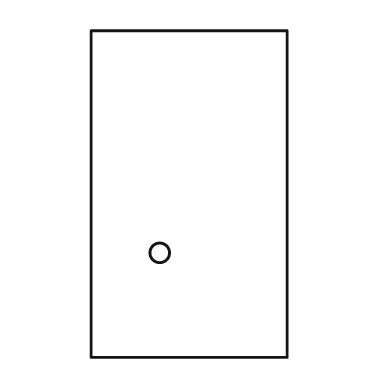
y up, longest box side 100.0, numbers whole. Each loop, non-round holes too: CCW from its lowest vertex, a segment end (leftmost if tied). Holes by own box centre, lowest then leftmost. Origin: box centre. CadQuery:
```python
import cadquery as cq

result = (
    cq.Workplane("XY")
    .moveTo(-30.0, -50.0)
    .lineTo(30.0, -50.0)
    .lineTo(30.0, 50.0)
    .lineTo(-30.0, 50.0)
    .close()
    .moveTo(-9.0, -18.0)
    .circle(3.0)
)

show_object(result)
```